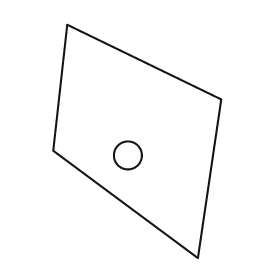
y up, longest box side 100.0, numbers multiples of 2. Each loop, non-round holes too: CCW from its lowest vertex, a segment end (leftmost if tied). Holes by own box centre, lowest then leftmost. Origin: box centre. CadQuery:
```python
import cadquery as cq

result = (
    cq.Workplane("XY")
    .moveTo(26.0, -50.0)
    .lineTo(36.0, 18.0)
    .lineTo(-30.0, 50.0)
    .lineTo(-36.0, -4.0)
    .close()
    .moveTo(-4.0, -6.0)
    .circle(6.0)
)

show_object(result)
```